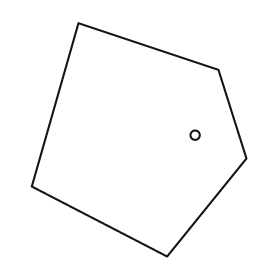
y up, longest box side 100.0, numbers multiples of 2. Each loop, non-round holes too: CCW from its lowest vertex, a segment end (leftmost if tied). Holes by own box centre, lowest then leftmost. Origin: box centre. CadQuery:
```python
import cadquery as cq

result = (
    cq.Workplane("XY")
    .moveTo(12.0, -50.0)
    .lineTo(46.0, -8.0)
    .lineTo(34.0, 30.0)
    .lineTo(-26.0, 50.0)
    .lineTo(-46.0, -20.0)
    .close()
    .moveTo(24.0, 2.0)
    .circle(2.0)
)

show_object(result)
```